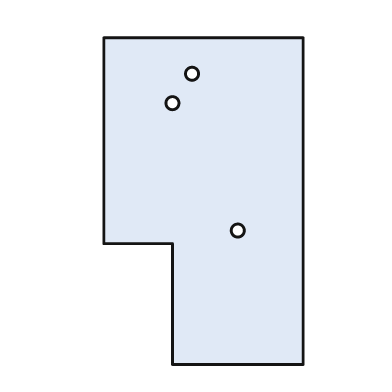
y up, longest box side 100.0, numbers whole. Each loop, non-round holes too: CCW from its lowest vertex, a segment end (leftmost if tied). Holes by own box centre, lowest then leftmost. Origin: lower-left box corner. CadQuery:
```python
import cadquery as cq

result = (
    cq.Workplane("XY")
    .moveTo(21.0, 0.0)
    .lineTo(61.0, 0.0)
    .lineTo(61.0, 100.0)
    .lineTo(0.0, 100.0)
    .lineTo(0.0, 37.0)
    .lineTo(21.0, 37.0)
    .close()
    .moveTo(41.0, 41.0)
    .circle(2.0)
    .moveTo(21.0, 80.0)
    .circle(2.0)
    .moveTo(27.0, 89.0)
    .circle(2.0)
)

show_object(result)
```